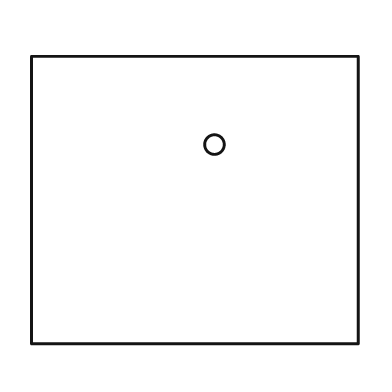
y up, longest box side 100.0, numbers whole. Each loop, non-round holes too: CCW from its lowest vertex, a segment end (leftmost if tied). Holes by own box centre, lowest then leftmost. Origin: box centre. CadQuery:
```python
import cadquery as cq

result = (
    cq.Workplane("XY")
    .moveTo(-50.0, -44.0)
    .lineTo(50.0, -44.0)
    .lineTo(50.0, 44.0)
    .lineTo(-50.0, 44.0)
    .close()
    .moveTo(6.0, 17.0)
    .circle(3.0)
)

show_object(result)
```